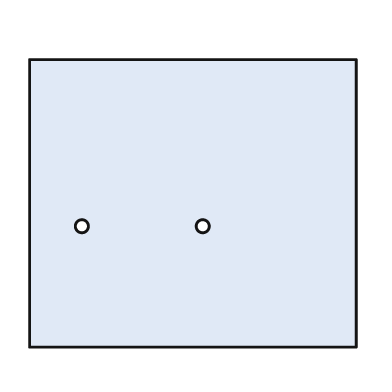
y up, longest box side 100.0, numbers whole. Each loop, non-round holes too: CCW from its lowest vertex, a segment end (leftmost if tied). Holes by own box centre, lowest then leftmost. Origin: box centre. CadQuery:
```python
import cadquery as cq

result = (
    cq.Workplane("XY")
    .moveTo(-50.0, -44.0)
    .lineTo(50.0, -44.0)
    .lineTo(50.0, 44.0)
    .lineTo(-50.0, 44.0)
    .close()
    .moveTo(-34.0, -7.0)
    .circle(2.0)
    .moveTo(3.0, -7.0)
    .circle(2.0)
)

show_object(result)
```